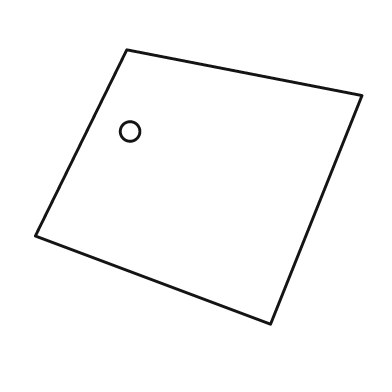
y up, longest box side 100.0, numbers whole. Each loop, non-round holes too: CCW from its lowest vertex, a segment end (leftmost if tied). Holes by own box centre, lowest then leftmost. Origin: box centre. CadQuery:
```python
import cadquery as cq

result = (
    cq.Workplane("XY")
    .moveTo(22.0, -42.0)
    .lineTo(50.0, 28.0)
    .lineTo(-22.0, 42.0)
    .lineTo(-50.0, -15.0)
    .close()
    .moveTo(-21.0, 17.0)
    .circle(3.0)
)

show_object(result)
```